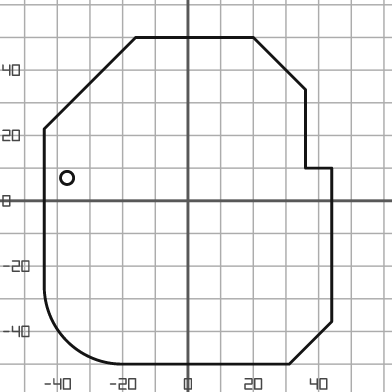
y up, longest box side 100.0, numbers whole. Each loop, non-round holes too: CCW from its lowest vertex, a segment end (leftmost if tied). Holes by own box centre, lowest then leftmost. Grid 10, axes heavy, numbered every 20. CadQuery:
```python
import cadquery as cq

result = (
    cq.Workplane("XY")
    .moveTo(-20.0, -50.0)
    .lineTo(31.0, -50.0)
    .lineTo(44.0, -37.0)
    .lineTo(44.0, 10.0)
    .lineTo(36.0, 10.0)
    .lineTo(36.0, 34.0)
    .lineTo(20.0, 50.0)
    .lineTo(-16.0, 50.0)
    .lineTo(-44.0, 22.0)
    .lineTo(-44.0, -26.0)
    .threePointArc((-37.0, -43.0), (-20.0, -50.0))
    .close()
    .moveTo(-37.0, 7.0)
    .circle(2.0)
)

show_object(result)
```